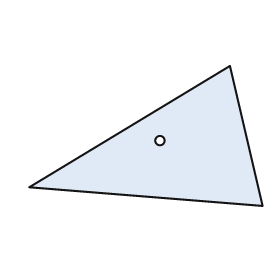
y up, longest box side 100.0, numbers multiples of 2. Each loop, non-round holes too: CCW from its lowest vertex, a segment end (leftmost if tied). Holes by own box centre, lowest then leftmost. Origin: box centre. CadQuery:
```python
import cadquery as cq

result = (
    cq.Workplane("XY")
    .moveTo(50.0, -30.0)
    .lineTo(36.0, 30.0)
    .lineTo(-50.0, -22.0)
    .close()
    .moveTo(6.0, -2.0)
    .circle(2.0)
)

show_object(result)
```